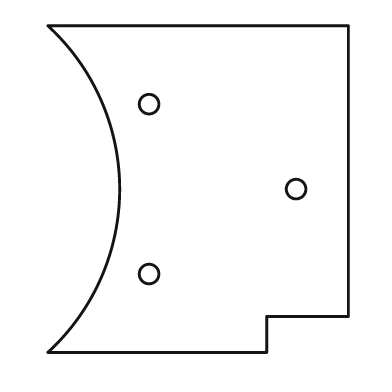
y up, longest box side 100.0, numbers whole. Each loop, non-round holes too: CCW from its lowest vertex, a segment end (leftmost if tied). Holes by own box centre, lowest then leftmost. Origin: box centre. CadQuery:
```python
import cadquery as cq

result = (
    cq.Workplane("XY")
    .moveTo(-46.0, -50.0)
    .lineTo(21.0, -50.0)
    .lineTo(21.0, -39.0)
    .lineTo(46.0, -39.0)
    .lineTo(46.0, 50.0)
    .lineTo(-46.0, 50.0)
    .threePointArc((-24.0, 0.0), (-46.0, -50.0))
    .close()
    .moveTo(-15.0, -26.0)
    .circle(3.0)
    .moveTo(30.0, 0.0)
    .circle(3.0)
    .moveTo(-15.0, 26.0)
    .circle(3.0)
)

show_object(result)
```